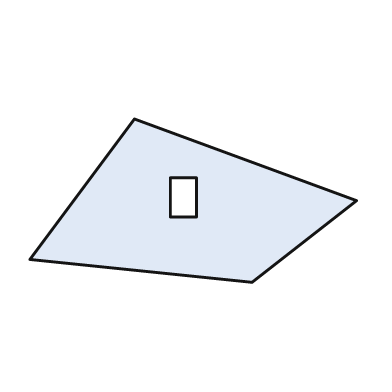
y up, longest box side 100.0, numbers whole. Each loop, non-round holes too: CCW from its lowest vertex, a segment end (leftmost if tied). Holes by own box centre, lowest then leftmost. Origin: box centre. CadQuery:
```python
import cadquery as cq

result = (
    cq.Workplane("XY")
    .moveTo(18.0, -25.0)
    .lineTo(50.0, 0.0)
    .lineTo(-18.0, 25.0)
    .lineTo(-50.0, -18.0)
    .close()
    .moveTo(-7.0, -5.0)
    .lineTo(1.0, -5.0)
    .lineTo(1.0, 7.0)
    .lineTo(-7.0, 7.0)
    .close()
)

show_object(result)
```